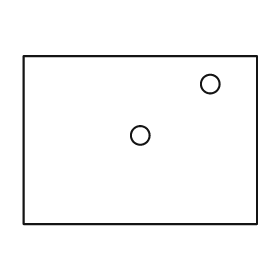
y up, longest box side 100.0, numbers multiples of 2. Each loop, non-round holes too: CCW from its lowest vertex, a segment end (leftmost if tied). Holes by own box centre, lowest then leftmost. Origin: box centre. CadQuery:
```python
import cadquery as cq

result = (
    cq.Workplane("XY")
    .moveTo(-50.0, -36.0)
    .lineTo(50.0, -36.0)
    .lineTo(50.0, 36.0)
    .lineTo(-50.0, 36.0)
    .close()
    .moveTo(0.0, 2.0)
    .circle(4.0)
    .moveTo(30.0, 24.0)
    .circle(4.0)
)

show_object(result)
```